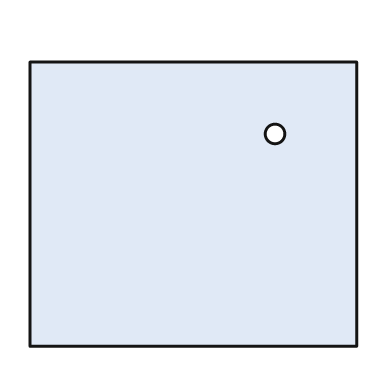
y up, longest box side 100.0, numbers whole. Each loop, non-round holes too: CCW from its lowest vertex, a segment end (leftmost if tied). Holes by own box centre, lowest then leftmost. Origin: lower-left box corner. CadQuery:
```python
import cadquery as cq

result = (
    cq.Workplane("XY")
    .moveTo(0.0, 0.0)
    .lineTo(100.0, 0.0)
    .lineTo(100.0, 87.0)
    .lineTo(0.0, 87.0)
    .close()
    .moveTo(75.0, 65.0)
    .circle(3.0)
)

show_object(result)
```